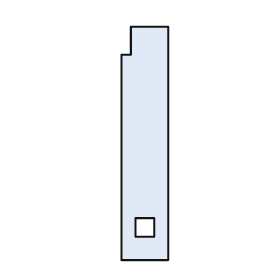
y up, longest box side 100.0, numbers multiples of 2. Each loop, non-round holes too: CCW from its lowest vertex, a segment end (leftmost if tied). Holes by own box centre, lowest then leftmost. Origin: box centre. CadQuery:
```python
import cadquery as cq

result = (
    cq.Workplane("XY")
    .moveTo(-10.0, -50.0)
    .lineTo(10.0, -50.0)
    .lineTo(10.0, 50.0)
    .lineTo(-6.0, 50.0)
    .lineTo(-6.0, 38.0)
    .lineTo(-10.0, 38.0)
    .close()
    .moveTo(-4.0, -40.0)
    .lineTo(4.0, -40.0)
    .lineTo(4.0, -32.0)
    .lineTo(-4.0, -32.0)
    .close()
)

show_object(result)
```